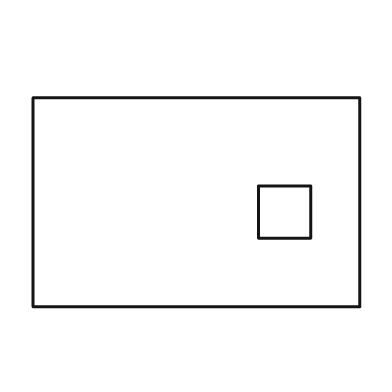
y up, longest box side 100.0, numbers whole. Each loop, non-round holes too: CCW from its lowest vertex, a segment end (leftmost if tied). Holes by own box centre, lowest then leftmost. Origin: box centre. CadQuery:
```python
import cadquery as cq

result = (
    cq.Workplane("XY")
    .moveTo(-50.0, -32.0)
    .lineTo(50.0, -32.0)
    .lineTo(50.0, 32.0)
    .lineTo(-50.0, 32.0)
    .close()
    .moveTo(19.0, -11.0)
    .lineTo(35.0, -11.0)
    .lineTo(35.0, 5.0)
    .lineTo(19.0, 5.0)
    .close()
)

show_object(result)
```